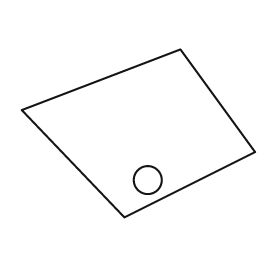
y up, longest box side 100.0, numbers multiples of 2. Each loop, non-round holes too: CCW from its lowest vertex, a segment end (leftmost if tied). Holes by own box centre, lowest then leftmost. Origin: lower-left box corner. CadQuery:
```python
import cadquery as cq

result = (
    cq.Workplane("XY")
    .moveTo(44.0, 0.0)
    .lineTo(100.0, 28.0)
    .lineTo(68.0, 72.0)
    .lineTo(0.0, 46.0)
    .close()
    .moveTo(54.0, 16.0)
    .circle(6.0)
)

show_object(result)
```